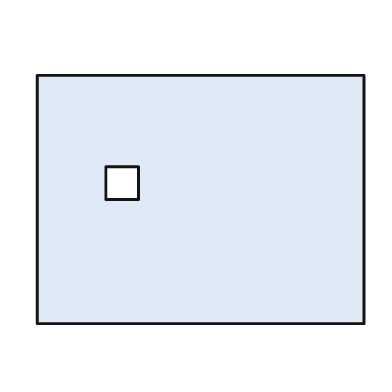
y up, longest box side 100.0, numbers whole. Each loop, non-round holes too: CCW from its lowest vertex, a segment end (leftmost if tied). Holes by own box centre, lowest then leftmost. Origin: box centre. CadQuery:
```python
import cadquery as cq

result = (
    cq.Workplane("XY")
    .moveTo(-50.0, -38.0)
    .lineTo(50.0, -38.0)
    .lineTo(50.0, 38.0)
    .lineTo(-50.0, 38.0)
    .close()
    .moveTo(-29.0, 0.0)
    .lineTo(-19.0, 0.0)
    .lineTo(-19.0, 10.0)
    .lineTo(-29.0, 10.0)
    .close()
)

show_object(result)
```